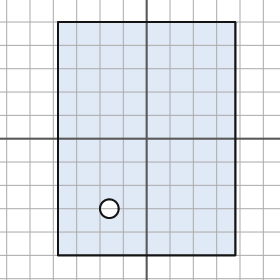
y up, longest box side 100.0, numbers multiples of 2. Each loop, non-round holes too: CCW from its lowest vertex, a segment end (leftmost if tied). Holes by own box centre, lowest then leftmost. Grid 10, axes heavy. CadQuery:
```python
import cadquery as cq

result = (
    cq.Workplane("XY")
    .moveTo(-38.0, -50.0)
    .lineTo(38.0, -50.0)
    .lineTo(38.0, 50.0)
    .lineTo(-38.0, 50.0)
    .close()
    .moveTo(-16.0, -30.0)
    .circle(4.0)
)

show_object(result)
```